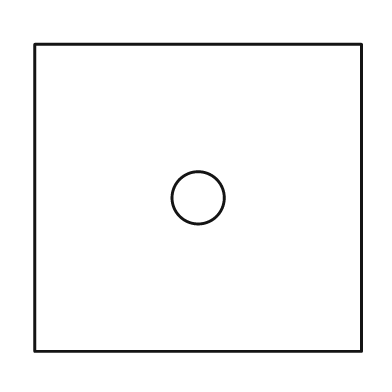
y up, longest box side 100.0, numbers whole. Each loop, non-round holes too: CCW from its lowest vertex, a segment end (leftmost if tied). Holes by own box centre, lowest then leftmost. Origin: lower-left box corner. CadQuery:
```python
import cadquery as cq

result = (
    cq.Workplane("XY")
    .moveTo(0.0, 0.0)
    .lineTo(100.0, 0.0)
    .lineTo(100.0, 94.0)
    .lineTo(0.0, 94.0)
    .close()
    .moveTo(50.0, 47.0)
    .circle(8.0)
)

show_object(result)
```